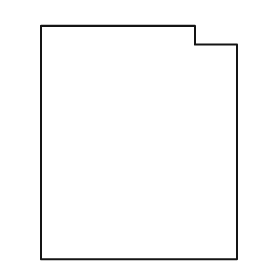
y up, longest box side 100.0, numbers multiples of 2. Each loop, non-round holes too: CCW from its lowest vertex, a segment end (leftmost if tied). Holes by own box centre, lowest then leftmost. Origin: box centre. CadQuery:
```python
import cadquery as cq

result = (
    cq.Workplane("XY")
    .moveTo(-42.0, -50.0)
    .lineTo(42.0, -50.0)
    .lineTo(42.0, 42.0)
    .lineTo(24.0, 42.0)
    .lineTo(24.0, 50.0)
    .lineTo(-42.0, 50.0)
    .close()
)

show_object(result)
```